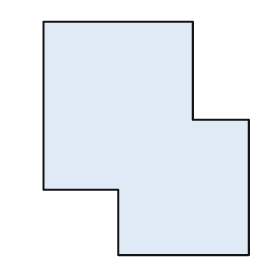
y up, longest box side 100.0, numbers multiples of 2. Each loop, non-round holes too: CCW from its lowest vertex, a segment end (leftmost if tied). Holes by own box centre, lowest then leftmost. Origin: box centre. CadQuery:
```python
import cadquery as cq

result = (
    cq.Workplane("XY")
    .moveTo(-12.0, -50.0)
    .lineTo(44.0, -50.0)
    .lineTo(44.0, 8.0)
    .lineTo(20.0, 8.0)
    .lineTo(20.0, 50.0)
    .lineTo(-44.0, 50.0)
    .lineTo(-44.0, -22.0)
    .lineTo(-12.0, -22.0)
    .close()
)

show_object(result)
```